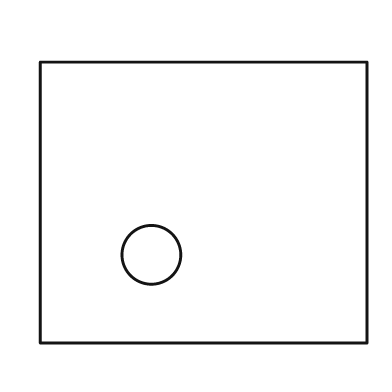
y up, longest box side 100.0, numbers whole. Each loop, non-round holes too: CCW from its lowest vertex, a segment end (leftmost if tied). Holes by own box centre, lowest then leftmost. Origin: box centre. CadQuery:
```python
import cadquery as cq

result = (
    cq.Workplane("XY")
    .moveTo(-50.0, -43.0)
    .lineTo(50.0, -43.0)
    .lineTo(50.0, 43.0)
    .lineTo(-50.0, 43.0)
    .close()
    .moveTo(-16.0, -16.0)
    .circle(9.0)
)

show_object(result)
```